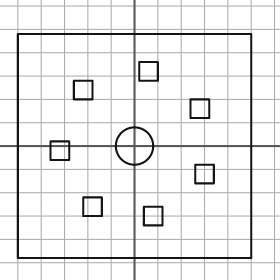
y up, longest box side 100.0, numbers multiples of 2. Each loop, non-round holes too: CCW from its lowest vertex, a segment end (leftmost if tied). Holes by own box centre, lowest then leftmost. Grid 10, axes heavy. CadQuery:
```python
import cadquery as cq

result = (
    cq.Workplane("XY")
    .moveTo(-50.0, -48.0)
    .lineTo(50.0, -48.0)
    .lineTo(50.0, 48.0)
    .lineTo(-50.0, 48.0)
    .close()
    .moveTo(4.0, -34.0)
    .lineTo(12.0, -34.0)
    .lineTo(12.0, -26.0)
    .lineTo(4.0, -26.0)
    .close()
    .moveTo(-22.0, -30.0)
    .lineTo(-14.0, -30.0)
    .lineTo(-14.0, -22.0)
    .lineTo(-22.0, -22.0)
    .close()
    .moveTo(26.0, -16.0)
    .lineTo(34.0, -16.0)
    .lineTo(34.0, -8.0)
    .lineTo(26.0, -8.0)
    .close()
    .moveTo(-36.0, -6.0)
    .lineTo(-28.0, -6.0)
    .lineTo(-28.0, 2.0)
    .lineTo(-36.0, 2.0)
    .close()
    .moveTo(0.0, 0.0)
    .circle(8.0)
    .moveTo(24.0, 12.0)
    .lineTo(32.0, 12.0)
    .lineTo(32.0, 20.0)
    .lineTo(24.0, 20.0)
    .close()
    .moveTo(-26.0, 20.0)
    .lineTo(-18.0, 20.0)
    .lineTo(-18.0, 28.0)
    .lineTo(-26.0, 28.0)
    .close()
    .moveTo(2.0, 28.0)
    .lineTo(10.0, 28.0)
    .lineTo(10.0, 36.0)
    .lineTo(2.0, 36.0)
    .close()
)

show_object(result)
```